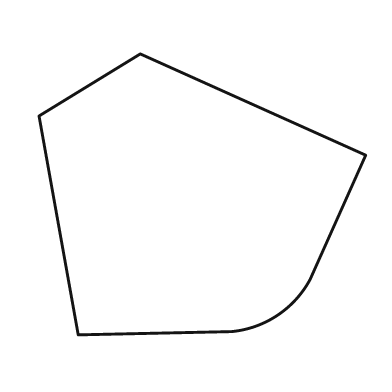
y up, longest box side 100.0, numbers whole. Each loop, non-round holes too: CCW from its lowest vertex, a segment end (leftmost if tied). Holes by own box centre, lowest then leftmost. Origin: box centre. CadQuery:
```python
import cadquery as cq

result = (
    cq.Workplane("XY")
    .moveTo(-38.0, -43.0)
    .lineTo(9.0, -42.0)
    .threePointArc((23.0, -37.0), (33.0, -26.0))
    .lineTo(50.0, 12.0)
    .lineTo(-19.0, 43.0)
    .lineTo(-50.0, 24.0)
    .close()
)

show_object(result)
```